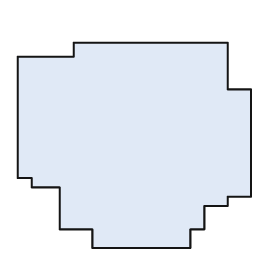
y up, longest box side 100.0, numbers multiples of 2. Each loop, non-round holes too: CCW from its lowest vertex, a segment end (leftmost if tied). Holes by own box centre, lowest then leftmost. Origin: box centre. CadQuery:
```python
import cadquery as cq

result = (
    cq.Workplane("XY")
    .moveTo(-18.0, -44.0)
    .lineTo(24.0, -44.0)
    .lineTo(24.0, -36.0)
    .lineTo(30.0, -36.0)
    .lineTo(30.0, -26.0)
    .lineTo(40.0, -26.0)
    .lineTo(40.0, -22.0)
    .lineTo(50.0, -22.0)
    .lineTo(50.0, 24.0)
    .lineTo(40.0, 24.0)
    .lineTo(40.0, 44.0)
    .lineTo(-26.0, 44.0)
    .lineTo(-26.0, 38.0)
    .lineTo(-50.0, 38.0)
    .lineTo(-50.0, -14.0)
    .lineTo(-44.0, -14.0)
    .lineTo(-44.0, -18.0)
    .lineTo(-32.0, -18.0)
    .lineTo(-32.0, -36.0)
    .lineTo(-18.0, -36.0)
    .close()
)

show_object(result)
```